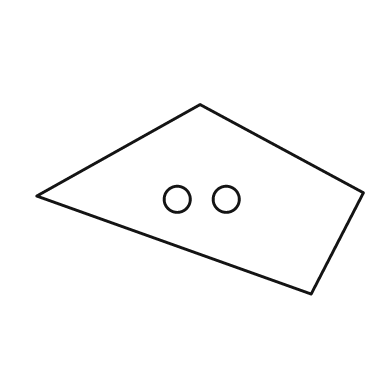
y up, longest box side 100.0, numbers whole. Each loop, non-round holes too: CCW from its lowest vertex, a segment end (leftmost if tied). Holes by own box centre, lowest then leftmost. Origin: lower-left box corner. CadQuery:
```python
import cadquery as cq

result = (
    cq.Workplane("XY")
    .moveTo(84.0, 0.0)
    .lineTo(100.0, 31.0)
    .lineTo(50.0, 58.0)
    .lineTo(0.0, 30.0)
    .close()
    .moveTo(43.0, 29.0)
    .circle(4.0)
    .moveTo(58.0, 29.0)
    .circle(4.0)
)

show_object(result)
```